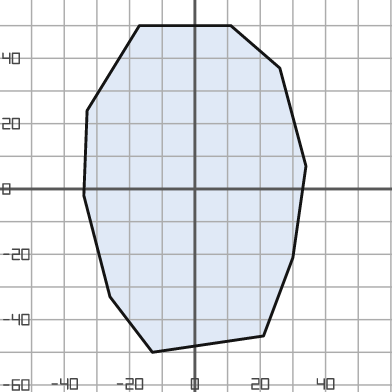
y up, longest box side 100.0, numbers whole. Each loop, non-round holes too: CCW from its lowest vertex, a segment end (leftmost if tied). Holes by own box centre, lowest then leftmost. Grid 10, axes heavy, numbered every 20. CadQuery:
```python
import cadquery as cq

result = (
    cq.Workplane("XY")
    .moveTo(-13.0, -50.0)
    .lineTo(21.0, -45.0)
    .lineTo(30.0, -21.0)
    .lineTo(34.0, 7.0)
    .lineTo(26.0, 37.0)
    .lineTo(11.0, 50.0)
    .lineTo(-17.0, 50.0)
    .lineTo(-33.0, 24.0)
    .lineTo(-34.0, -2.0)
    .lineTo(-26.0, -33.0)
    .close()
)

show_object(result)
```